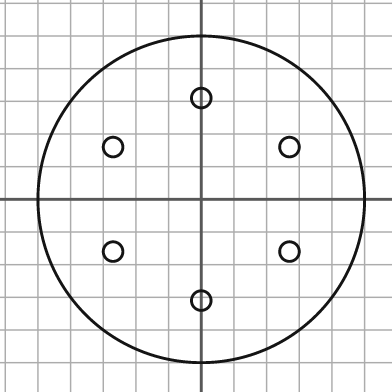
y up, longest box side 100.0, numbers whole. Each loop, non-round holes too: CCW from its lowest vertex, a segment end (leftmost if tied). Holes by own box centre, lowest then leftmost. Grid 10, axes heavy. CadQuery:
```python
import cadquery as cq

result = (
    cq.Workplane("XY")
    .moveTo(0.0, 0.0)
    .circle(50.0)
    .moveTo(0.0, -31.0)
    .circle(3.0)
    .moveTo(-27.0, -16.0)
    .circle(3.0)
    .moveTo(27.0, -16.0)
    .circle(3.0)
    .moveTo(-27.0, 16.0)
    .circle(3.0)
    .moveTo(27.0, 16.0)
    .circle(3.0)
    .moveTo(0.0, 31.0)
    .circle(3.0)
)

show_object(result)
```